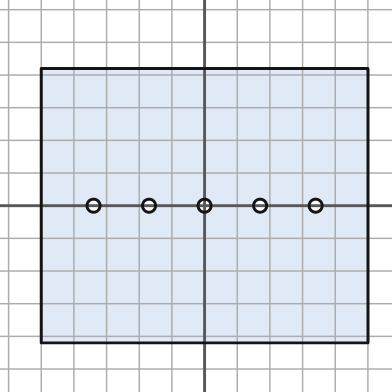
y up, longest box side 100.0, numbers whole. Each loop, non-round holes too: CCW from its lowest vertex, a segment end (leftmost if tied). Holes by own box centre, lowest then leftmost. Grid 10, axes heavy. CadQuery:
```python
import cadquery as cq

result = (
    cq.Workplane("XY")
    .moveTo(-50.0, -42.0)
    .lineTo(50.0, -42.0)
    .lineTo(50.0, 42.0)
    .lineTo(-50.0, 42.0)
    .close()
    .moveTo(-34.0, 0.0)
    .circle(2.0)
    .moveTo(-17.0, 0.0)
    .circle(2.0)
    .moveTo(0.0, 0.0)
    .circle(2.0)
    .moveTo(17.0, 0.0)
    .circle(2.0)
    .moveTo(34.0, 0.0)
    .circle(2.0)
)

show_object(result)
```